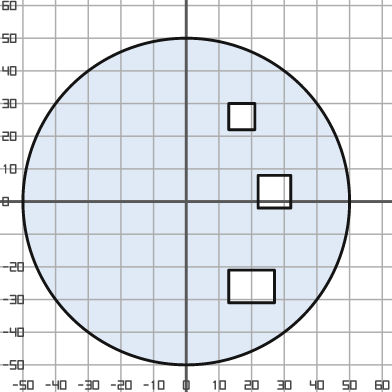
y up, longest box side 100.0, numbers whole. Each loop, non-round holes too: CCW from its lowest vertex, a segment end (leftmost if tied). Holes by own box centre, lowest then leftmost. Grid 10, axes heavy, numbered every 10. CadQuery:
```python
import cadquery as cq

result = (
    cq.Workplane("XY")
    .moveTo(0.0, 0.0)
    .circle(50.0)
    .moveTo(13.0, -31.0)
    .lineTo(27.0, -31.0)
    .lineTo(27.0, -21.0)
    .lineTo(13.0, -21.0)
    .close()
    .moveTo(22.0, -2.0)
    .lineTo(32.0, -2.0)
    .lineTo(32.0, 8.0)
    .lineTo(22.0, 8.0)
    .close()
    .moveTo(13.0, 22.0)
    .lineTo(21.0, 22.0)
    .lineTo(21.0, 30.0)
    .lineTo(13.0, 30.0)
    .close()
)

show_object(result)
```